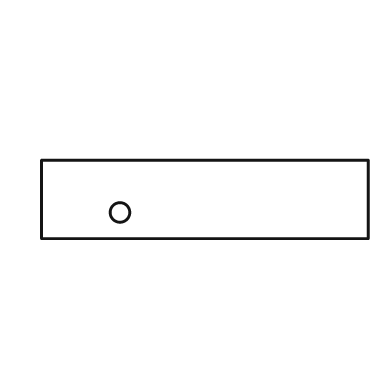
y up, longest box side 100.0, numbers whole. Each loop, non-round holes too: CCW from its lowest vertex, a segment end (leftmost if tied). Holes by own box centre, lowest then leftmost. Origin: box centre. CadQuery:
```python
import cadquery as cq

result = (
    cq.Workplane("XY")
    .moveTo(-50.0, -12.0)
    .lineTo(50.0, -12.0)
    .lineTo(50.0, 12.0)
    .lineTo(-50.0, 12.0)
    .close()
    .moveTo(-26.0, -4.0)
    .circle(3.0)
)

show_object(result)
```